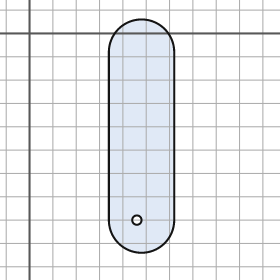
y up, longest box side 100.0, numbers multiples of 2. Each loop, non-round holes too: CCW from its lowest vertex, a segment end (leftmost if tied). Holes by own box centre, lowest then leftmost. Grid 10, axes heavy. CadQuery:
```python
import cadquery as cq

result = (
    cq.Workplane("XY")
    .moveTo(34.0, -80.0)
    .threePointArc((48.0, -94.0), (62.0, -80.0))
    .lineTo(62.0, -8.0)
    .threePointArc((48.0, 6.0), (34.0, -8.0))
    .close()
    .moveTo(46.0, -80.0)
    .circle(2.0)
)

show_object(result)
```